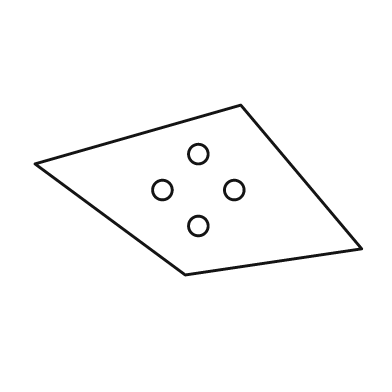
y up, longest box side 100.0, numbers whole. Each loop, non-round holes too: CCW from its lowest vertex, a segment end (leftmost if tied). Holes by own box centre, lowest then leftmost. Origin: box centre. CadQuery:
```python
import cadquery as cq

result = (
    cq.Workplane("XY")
    .moveTo(-4.0, -26.0)
    .lineTo(50.0, -18.0)
    .lineTo(13.0, 26.0)
    .lineTo(-50.0, 8.0)
    .close()
    .moveTo(0.0, -11.0)
    .circle(3.0)
    .moveTo(-11.0, 0.0)
    .circle(3.0)
    .moveTo(11.0, 0.0)
    .circle(3.0)
    .moveTo(0.0, 11.0)
    .circle(3.0)
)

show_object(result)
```